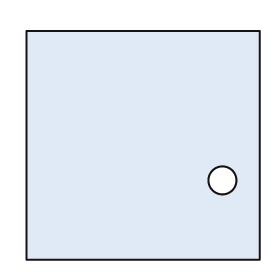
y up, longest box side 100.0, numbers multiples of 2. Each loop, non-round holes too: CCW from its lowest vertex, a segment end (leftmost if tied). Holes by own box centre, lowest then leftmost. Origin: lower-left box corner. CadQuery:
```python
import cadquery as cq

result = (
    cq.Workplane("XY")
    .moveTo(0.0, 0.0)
    .lineTo(100.0, 0.0)
    .lineTo(100.0, 98.0)
    .lineTo(0.0, 98.0)
    .close()
    .moveTo(84.0, 34.0)
    .circle(6.0)
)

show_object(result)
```